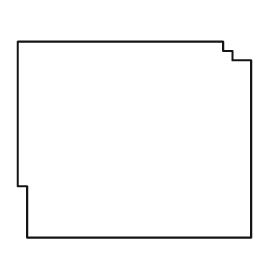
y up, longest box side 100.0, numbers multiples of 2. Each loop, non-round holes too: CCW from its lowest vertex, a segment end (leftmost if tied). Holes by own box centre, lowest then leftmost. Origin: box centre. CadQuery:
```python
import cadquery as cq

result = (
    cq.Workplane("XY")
    .moveTo(-46.0, -42.0)
    .lineTo(50.0, -42.0)
    .lineTo(50.0, 34.0)
    .lineTo(42.0, 34.0)
    .lineTo(42.0, 38.0)
    .lineTo(38.0, 38.0)
    .lineTo(38.0, 42.0)
    .lineTo(-50.0, 42.0)
    .lineTo(-50.0, -20.0)
    .lineTo(-46.0, -20.0)
    .close()
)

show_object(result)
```